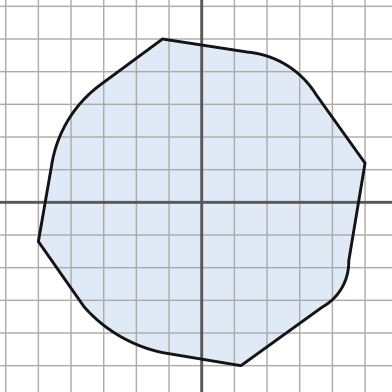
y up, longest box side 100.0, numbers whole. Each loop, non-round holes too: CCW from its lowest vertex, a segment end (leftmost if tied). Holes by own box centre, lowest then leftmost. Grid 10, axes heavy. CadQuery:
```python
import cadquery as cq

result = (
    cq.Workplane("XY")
    .moveTo(12.0, -50.0)
    .lineTo(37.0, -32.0)
    .threePointArc((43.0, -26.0), (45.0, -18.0))
    .lineTo(50.0, 12.0)
    .lineTo(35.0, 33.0)
    .threePointArc((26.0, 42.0), (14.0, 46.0))
    .lineTo(-12.0, 50.0)
    .lineTo(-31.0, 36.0)
    .threePointArc((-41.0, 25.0), (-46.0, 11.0))
    .lineTo(-50.0, -12.0)
    .lineTo(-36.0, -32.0)
    .threePointArc((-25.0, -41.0), (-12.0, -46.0))
    .close()
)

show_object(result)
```